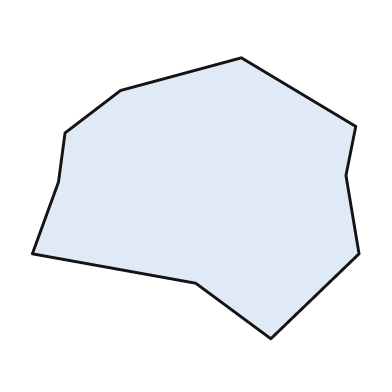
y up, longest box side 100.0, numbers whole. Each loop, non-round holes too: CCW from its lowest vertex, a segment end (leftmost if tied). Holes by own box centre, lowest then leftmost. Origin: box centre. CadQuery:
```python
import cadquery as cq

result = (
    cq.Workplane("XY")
    .moveTo(23.0, -43.0)
    .lineTo(50.0, -17.0)
    .lineTo(46.0, 7.0)
    .lineTo(49.0, 22.0)
    .lineTo(14.0, 43.0)
    .lineTo(-23.0, 33.0)
    .lineTo(-40.0, 20.0)
    .lineTo(-42.0, 5.0)
    .lineTo(-50.0, -17.0)
    .lineTo(0.0, -26.0)
    .close()
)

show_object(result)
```